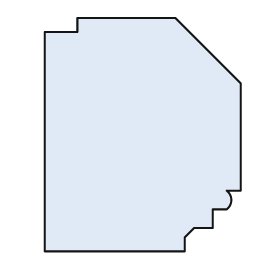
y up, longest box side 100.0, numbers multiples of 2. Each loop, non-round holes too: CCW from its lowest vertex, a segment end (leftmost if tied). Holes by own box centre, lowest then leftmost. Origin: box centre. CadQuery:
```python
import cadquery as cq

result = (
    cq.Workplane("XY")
    .moveTo(-42.0, -50.0)
    .lineTo(18.0, -50.0)
    .lineTo(18.0, -44.0)
    .lineTo(22.0, -40.0)
    .lineTo(30.0, -40.0)
    .lineTo(30.0, -32.0)
    .lineTo(36.0, -32.0)
    .threePointArc((38.0, -28.0), (36.0, -24.0))
    .lineTo(42.0, -24.0)
    .lineTo(42.0, 22.0)
    .lineTo(14.0, 50.0)
    .lineTo(-28.0, 50.0)
    .lineTo(-28.0, 44.0)
    .lineTo(-42.0, 44.0)
    .close()
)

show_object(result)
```